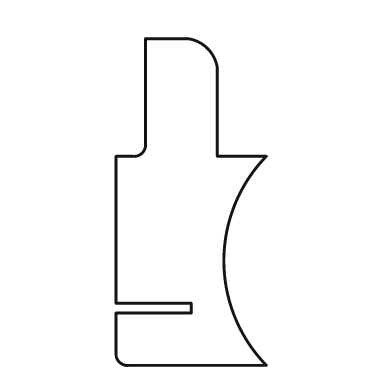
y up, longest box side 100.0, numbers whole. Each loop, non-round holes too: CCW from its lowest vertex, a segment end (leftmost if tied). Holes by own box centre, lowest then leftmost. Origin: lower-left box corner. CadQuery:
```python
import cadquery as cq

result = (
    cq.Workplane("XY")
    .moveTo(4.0, 0.0)
    .lineTo(46.0, 0.0)
    .threePointArc((33.0, 32.0), (46.0, 64.0))
    .lineTo(31.0, 64.0)
    .lineTo(31.0, 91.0)
    .threePointArc((28.0, 97.0), (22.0, 100.0))
    .lineTo(9.0, 100.0)
    .lineTo(9.0, 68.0)
    .threePointArc((8.0, 65.0), (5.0, 64.0))
    .lineTo(0.0, 64.0)
    .lineTo(0.0, 19.0)
    .lineTo(23.0, 19.0)
    .lineTo(23.0, 16.0)
    .lineTo(0.0, 16.0)
    .lineTo(0.0, 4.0)
    .threePointArc((1.0, 1.0), (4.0, 0.0))
    .close()
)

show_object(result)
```